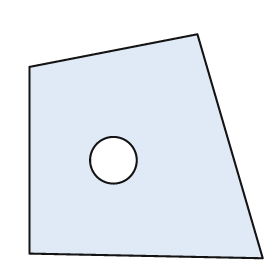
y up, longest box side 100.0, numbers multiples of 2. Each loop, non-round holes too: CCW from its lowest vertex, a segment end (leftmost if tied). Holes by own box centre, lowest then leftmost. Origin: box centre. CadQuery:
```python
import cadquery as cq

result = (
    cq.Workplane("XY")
    .moveTo(50.0, -48.0)
    .lineTo(22.0, 48.0)
    .lineTo(-50.0, 34.0)
    .lineTo(-50.0, -46.0)
    .close()
    .moveTo(-14.0, -6.0)
    .circle(10.0)
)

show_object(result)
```